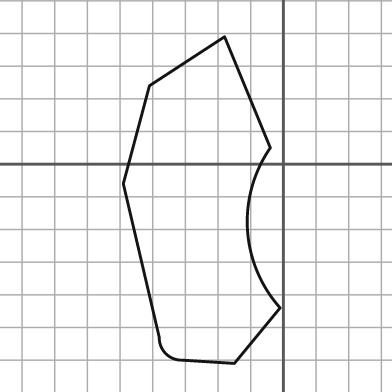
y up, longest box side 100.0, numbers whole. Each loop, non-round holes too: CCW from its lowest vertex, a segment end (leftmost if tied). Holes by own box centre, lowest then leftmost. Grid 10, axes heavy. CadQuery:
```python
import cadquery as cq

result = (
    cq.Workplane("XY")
    .moveTo(-15.0, -61.0)
    .lineTo(-1.0, -44.0)
    .threePointArc((-11.0, -20.0), (-4.0, 5.0))
    .lineTo(-18.0, 39.0)
    .lineTo(-41.0, 24.0)
    .lineTo(-49.0, -6.0)
    .lineTo(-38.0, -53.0)
    .threePointArc((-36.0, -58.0), (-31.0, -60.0))
    .close()
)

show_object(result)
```